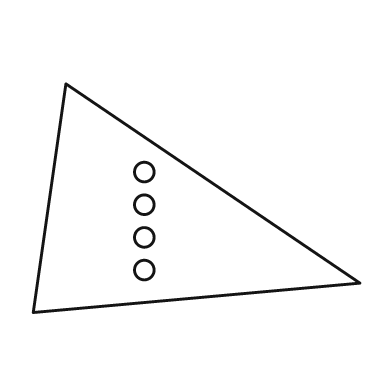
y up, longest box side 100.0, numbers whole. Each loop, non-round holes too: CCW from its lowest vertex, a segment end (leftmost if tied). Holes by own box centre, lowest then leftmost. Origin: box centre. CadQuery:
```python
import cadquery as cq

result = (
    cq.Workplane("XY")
    .moveTo(-50.0, -35.0)
    .lineTo(50.0, -26.0)
    .lineTo(-40.0, 35.0)
    .close()
    .moveTo(-16.0, -22.0)
    .circle(3.0)
    .moveTo(-16.0, -12.0)
    .circle(3.0)
    .moveTo(-16.0, -2.0)
    .circle(3.0)
    .moveTo(-16.0, 8.0)
    .circle(3.0)
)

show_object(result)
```